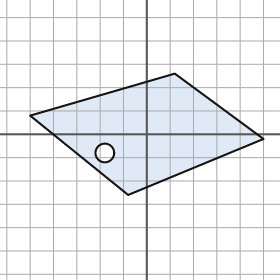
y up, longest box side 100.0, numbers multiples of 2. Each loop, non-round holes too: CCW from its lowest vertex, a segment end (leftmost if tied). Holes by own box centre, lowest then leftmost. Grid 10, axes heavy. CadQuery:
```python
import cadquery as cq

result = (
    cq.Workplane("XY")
    .moveTo(-8.0, -26.0)
    .lineTo(50.0, -2.0)
    .lineTo(12.0, 26.0)
    .lineTo(-50.0, 8.0)
    .close()
    .moveTo(-18.0, -8.0)
    .circle(4.0)
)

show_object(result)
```